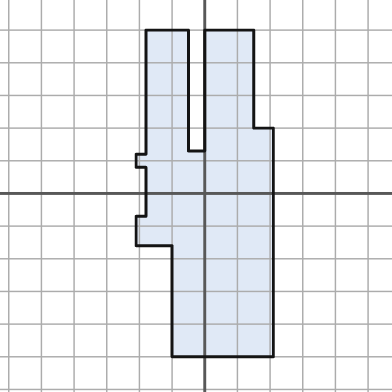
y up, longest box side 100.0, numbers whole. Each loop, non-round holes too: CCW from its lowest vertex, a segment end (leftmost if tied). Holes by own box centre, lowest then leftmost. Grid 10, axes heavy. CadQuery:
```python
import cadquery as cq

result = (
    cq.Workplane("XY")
    .moveTo(-10.0, -50.0)
    .lineTo(21.0, -50.0)
    .lineTo(21.0, 20.0)
    .lineTo(15.0, 20.0)
    .lineTo(15.0, 50.0)
    .lineTo(0.0, 50.0)
    .lineTo(0.0, 13.0)
    .lineTo(-5.0, 13.0)
    .lineTo(-5.0, 50.0)
    .lineTo(-18.0, 50.0)
    .lineTo(-18.0, 12.0)
    .lineTo(-21.0, 12.0)
    .lineTo(-21.0, 8.0)
    .lineTo(-18.0, 8.0)
    .lineTo(-18.0, -7.0)
    .lineTo(-21.0, -7.0)
    .lineTo(-21.0, -16.0)
    .lineTo(-10.0, -16.0)
    .close()
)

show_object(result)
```